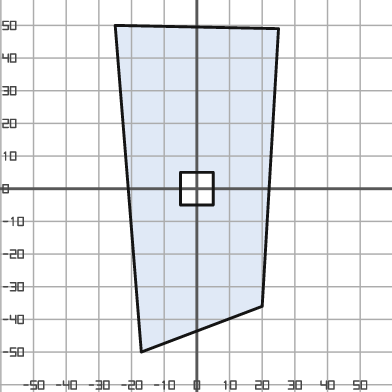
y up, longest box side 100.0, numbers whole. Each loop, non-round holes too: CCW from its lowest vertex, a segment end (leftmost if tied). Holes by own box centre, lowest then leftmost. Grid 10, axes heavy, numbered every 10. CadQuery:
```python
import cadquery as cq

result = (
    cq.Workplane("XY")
    .moveTo(-17.0, -50.0)
    .lineTo(20.0, -36.0)
    .lineTo(25.0, 49.0)
    .lineTo(-25.0, 50.0)
    .close()
    .moveTo(-5.0, -5.0)
    .lineTo(5.0, -5.0)
    .lineTo(5.0, 5.0)
    .lineTo(-5.0, 5.0)
    .close()
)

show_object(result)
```